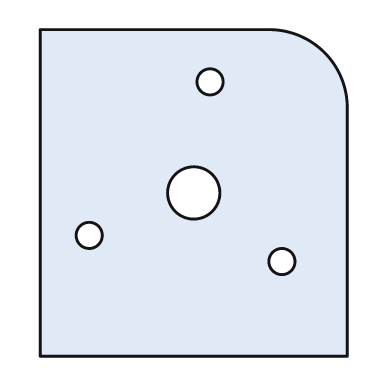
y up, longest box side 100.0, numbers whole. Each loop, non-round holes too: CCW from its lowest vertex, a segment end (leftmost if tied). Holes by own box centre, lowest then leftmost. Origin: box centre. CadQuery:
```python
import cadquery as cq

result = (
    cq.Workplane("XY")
    .moveTo(-47.0, -50.0)
    .lineTo(47.0, -50.0)
    .lineTo(47.0, 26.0)
    .threePointArc((40.0, 43.0), (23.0, 50.0))
    .lineTo(-47.0, 50.0)
    .close()
    .moveTo(27.0, -21.0)
    .circle(4.0)
    .moveTo(-32.0, -13.0)
    .circle(4.0)
    .moveTo(0.0, 0.0)
    .circle(8.0)
    .moveTo(5.0, 34.0)
    .circle(4.0)
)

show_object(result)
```